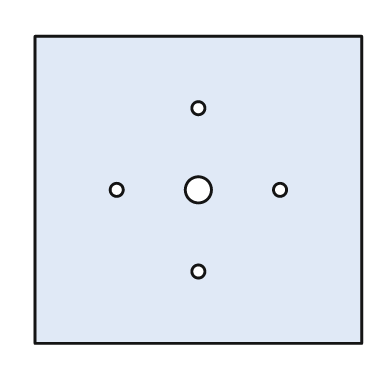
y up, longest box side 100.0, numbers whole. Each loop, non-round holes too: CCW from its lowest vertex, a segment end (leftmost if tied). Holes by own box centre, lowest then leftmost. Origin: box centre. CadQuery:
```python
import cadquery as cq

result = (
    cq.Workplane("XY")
    .moveTo(-50.0, -47.0)
    .lineTo(50.0, -47.0)
    .lineTo(50.0, 47.0)
    .lineTo(-50.0, 47.0)
    .close()
    .moveTo(0.0, -25.0)
    .circle(2.0)
    .moveTo(-25.0, 0.0)
    .circle(2.0)
    .moveTo(0.0, 0.0)
    .circle(4.0)
    .moveTo(25.0, 0.0)
    .circle(2.0)
    .moveTo(0.0, 25.0)
    .circle(2.0)
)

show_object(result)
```